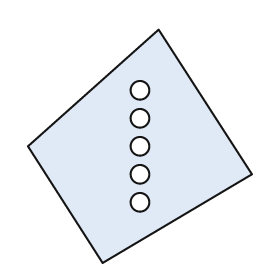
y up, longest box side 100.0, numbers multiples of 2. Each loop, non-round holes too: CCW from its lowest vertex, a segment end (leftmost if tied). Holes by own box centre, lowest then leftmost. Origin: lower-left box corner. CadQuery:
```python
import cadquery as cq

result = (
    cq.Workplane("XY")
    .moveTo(32.0, 0.0)
    .lineTo(96.0, 38.0)
    .lineTo(56.0, 100.0)
    .lineTo(0.0, 50.0)
    .close()
    .moveTo(48.0, 26.0)
    .circle(4.0)
    .moveTo(48.0, 38.0)
    .circle(4.0)
    .moveTo(48.0, 50.0)
    .circle(4.0)
    .moveTo(48.0, 62.0)
    .circle(4.0)
    .moveTo(48.0, 74.0)
    .circle(4.0)
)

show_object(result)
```